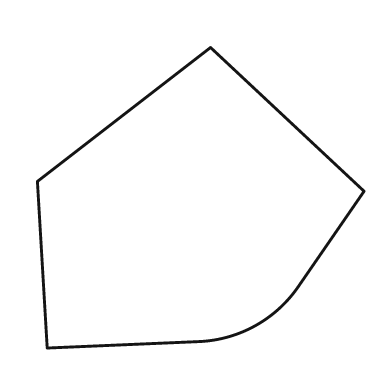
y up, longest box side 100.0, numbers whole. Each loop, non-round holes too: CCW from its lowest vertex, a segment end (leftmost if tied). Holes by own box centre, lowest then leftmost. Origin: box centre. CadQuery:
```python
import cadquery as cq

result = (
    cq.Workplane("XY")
    .moveTo(-47.0, -46.0)
    .lineTo(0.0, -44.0)
    .threePointArc((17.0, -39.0), (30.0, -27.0))
    .lineTo(50.0, 2.0)
    .lineTo(3.0, 46.0)
    .lineTo(-50.0, 5.0)
    .close()
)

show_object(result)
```